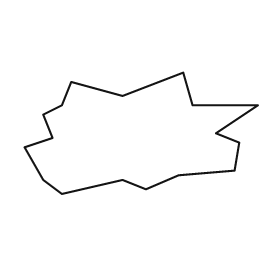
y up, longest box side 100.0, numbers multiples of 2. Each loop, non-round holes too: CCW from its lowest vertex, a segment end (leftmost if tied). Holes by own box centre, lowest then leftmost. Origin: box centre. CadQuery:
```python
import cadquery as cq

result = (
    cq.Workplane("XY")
    .moveTo(-34.0, -26.0)
    .lineTo(-8.0, -20.0)
    .lineTo(2.0, -24.0)
    .lineTo(16.0, -18.0)
    .lineTo(40.0, -16.0)
    .lineTo(42.0, -4.0)
    .lineTo(32.0, 0.0)
    .lineTo(50.0, 12.0)
    .lineTo(22.0, 12.0)
    .lineTo(18.0, 26.0)
    .lineTo(-8.0, 16.0)
    .lineTo(-30.0, 22.0)
    .lineTo(-34.0, 12.0)
    .lineTo(-42.0, 8.0)
    .lineTo(-38.0, -2.0)
    .lineTo(-50.0, -6.0)
    .lineTo(-42.0, -20.0)
    .close()
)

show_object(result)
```